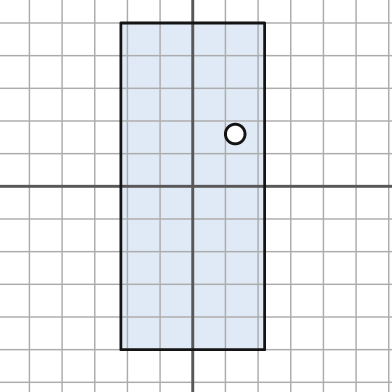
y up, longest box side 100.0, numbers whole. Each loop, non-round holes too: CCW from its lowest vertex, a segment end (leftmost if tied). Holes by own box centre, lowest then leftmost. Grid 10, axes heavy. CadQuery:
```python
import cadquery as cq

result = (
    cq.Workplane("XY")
    .moveTo(-22.0, -50.0)
    .lineTo(22.0, -50.0)
    .lineTo(22.0, 50.0)
    .lineTo(-22.0, 50.0)
    .close()
    .moveTo(13.0, 16.0)
    .circle(3.0)
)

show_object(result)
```